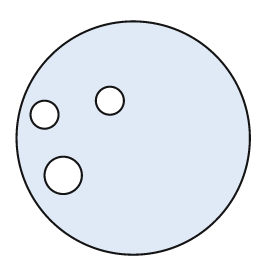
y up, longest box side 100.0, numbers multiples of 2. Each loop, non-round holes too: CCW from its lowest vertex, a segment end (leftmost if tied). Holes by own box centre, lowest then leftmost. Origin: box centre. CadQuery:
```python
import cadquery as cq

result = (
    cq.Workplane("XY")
    .moveTo(0.0, 0.0)
    .circle(50.0)
    .moveTo(-30.0, -16.0)
    .circle(8.0)
    .moveTo(-38.0, 10.0)
    .circle(6.0)
    .moveTo(-10.0, 16.0)
    .circle(6.0)
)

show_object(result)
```